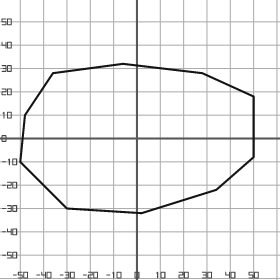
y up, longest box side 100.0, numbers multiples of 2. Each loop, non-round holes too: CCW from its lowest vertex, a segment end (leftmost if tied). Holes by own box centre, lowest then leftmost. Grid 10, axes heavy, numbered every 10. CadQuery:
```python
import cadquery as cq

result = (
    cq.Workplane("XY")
    .moveTo(2.0, -32.0)
    .lineTo(34.0, -22.0)
    .lineTo(50.0, -8.0)
    .lineTo(50.0, 18.0)
    .lineTo(28.0, 28.0)
    .lineTo(-6.0, 32.0)
    .lineTo(-36.0, 28.0)
    .lineTo(-48.0, 10.0)
    .lineTo(-50.0, -10.0)
    .lineTo(-30.0, -30.0)
    .close()
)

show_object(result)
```